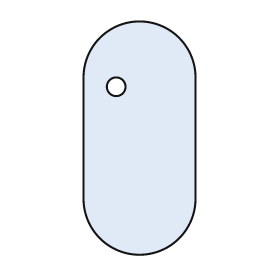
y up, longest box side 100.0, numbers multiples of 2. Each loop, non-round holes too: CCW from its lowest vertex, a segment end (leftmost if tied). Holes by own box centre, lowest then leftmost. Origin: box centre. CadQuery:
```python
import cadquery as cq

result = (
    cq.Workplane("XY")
    .moveTo(-24.0, -26.0)
    .threePointArc((0.0, -50.0), (24.0, -26.0))
    .lineTo(24.0, 26.0)
    .threePointArc((0.0, 50.0), (-24.0, 26.0))
    .close()
    .moveTo(-10.0, 22.0)
    .circle(4.0)
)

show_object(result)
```